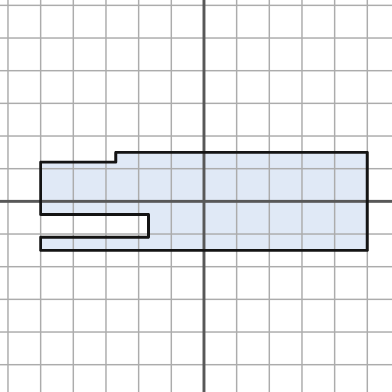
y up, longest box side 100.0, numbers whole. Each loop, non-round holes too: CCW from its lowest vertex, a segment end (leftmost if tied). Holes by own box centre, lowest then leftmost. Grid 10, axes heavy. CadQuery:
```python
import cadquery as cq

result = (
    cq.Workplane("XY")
    .moveTo(-50.0, -15.0)
    .lineTo(50.0, -15.0)
    .lineTo(50.0, 15.0)
    .lineTo(-27.0, 15.0)
    .lineTo(-27.0, 12.0)
    .lineTo(-50.0, 12.0)
    .lineTo(-50.0, -4.0)
    .lineTo(-17.0, -4.0)
    .lineTo(-17.0, -11.0)
    .lineTo(-50.0, -11.0)
    .close()
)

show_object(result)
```